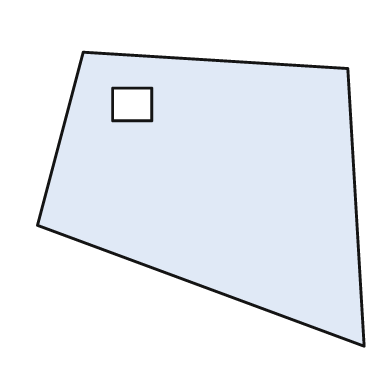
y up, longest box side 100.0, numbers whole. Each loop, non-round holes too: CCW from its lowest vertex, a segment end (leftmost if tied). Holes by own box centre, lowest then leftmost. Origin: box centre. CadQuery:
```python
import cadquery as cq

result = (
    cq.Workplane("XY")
    .moveTo(50.0, -45.0)
    .lineTo(45.0, 40.0)
    .lineTo(-36.0, 45.0)
    .lineTo(-50.0, -8.0)
    .close()
    .moveTo(-27.0, 24.0)
    .lineTo(-15.0, 24.0)
    .lineTo(-15.0, 34.0)
    .lineTo(-27.0, 34.0)
    .close()
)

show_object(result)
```